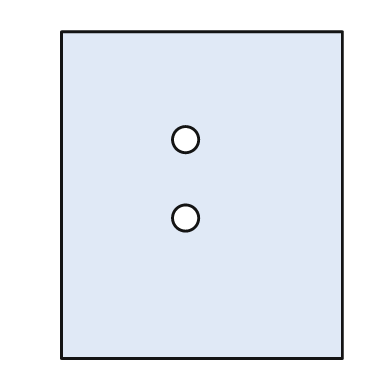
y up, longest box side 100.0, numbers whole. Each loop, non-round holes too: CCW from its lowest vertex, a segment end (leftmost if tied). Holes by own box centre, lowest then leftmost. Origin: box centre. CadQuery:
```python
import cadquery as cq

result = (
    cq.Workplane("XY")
    .moveTo(-43.0, -50.0)
    .lineTo(43.0, -50.0)
    .lineTo(43.0, 50.0)
    .lineTo(-43.0, 50.0)
    .close()
    .moveTo(-5.0, -7.0)
    .circle(4.0)
    .moveTo(-5.0, 17.0)
    .circle(4.0)
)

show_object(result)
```